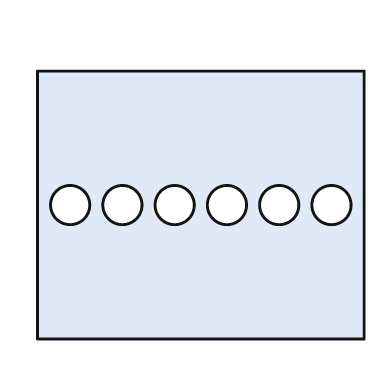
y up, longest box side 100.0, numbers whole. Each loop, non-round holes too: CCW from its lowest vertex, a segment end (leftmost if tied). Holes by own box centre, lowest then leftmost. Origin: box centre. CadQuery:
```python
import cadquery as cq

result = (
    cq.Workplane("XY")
    .moveTo(-50.0, -41.0)
    .lineTo(50.0, -41.0)
    .lineTo(50.0, 41.0)
    .lineTo(-50.0, 41.0)
    .close()
    .moveTo(-40.0, 0.0)
    .circle(6.0)
    .moveTo(-24.0, 0.0)
    .circle(6.0)
    .moveTo(-8.0, 0.0)
    .circle(6.0)
    .moveTo(8.0, 0.0)
    .circle(6.0)
    .moveTo(24.0, 0.0)
    .circle(6.0)
    .moveTo(40.0, 0.0)
    .circle(6.0)
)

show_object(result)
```